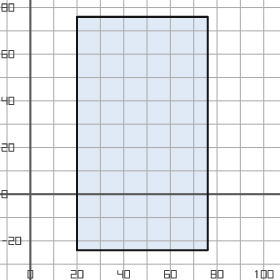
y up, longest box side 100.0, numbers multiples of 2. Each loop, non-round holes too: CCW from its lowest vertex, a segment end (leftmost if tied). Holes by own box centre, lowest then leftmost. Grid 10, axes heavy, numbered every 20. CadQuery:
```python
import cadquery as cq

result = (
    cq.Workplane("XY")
    .moveTo(20.0, -24.0)
    .lineTo(76.0, -24.0)
    .lineTo(76.0, 76.0)
    .lineTo(20.0, 76.0)
    .close()
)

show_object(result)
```